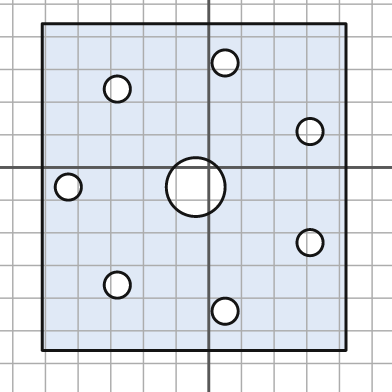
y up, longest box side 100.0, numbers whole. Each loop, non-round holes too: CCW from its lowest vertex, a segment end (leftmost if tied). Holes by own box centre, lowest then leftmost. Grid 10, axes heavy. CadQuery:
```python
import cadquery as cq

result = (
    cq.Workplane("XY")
    .moveTo(-51.0, -56.0)
    .lineTo(42.0, -56.0)
    .lineTo(42.0, 44.0)
    .lineTo(-51.0, 44.0)
    .close()
    .moveTo(5.0, -44.0)
    .circle(4.0)
    .moveTo(-28.0, -36.0)
    .circle(4.0)
    .moveTo(31.0, -23.0)
    .circle(4.0)
    .moveTo(-43.0, -6.0)
    .circle(4.0)
    .moveTo(-4.0, -6.0)
    .circle(9.0)
    .moveTo(31.0, 11.0)
    .circle(4.0)
    .moveTo(-28.0, 24.0)
    .circle(4.0)
    .moveTo(5.0, 32.0)
    .circle(4.0)
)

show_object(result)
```